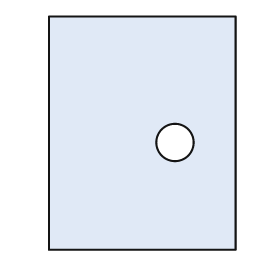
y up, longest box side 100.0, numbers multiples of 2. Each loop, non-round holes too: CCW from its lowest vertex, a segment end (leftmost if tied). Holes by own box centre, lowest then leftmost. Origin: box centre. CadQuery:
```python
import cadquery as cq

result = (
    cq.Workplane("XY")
    .moveTo(-40.0, -50.0)
    .lineTo(40.0, -50.0)
    .lineTo(40.0, 50.0)
    .lineTo(-40.0, 50.0)
    .close()
    .moveTo(14.0, -4.0)
    .circle(8.0)
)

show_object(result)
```